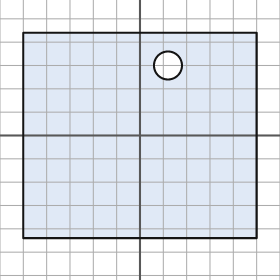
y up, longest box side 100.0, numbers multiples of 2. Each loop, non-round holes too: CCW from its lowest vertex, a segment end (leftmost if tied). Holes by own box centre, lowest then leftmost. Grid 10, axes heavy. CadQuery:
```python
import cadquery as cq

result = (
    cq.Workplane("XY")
    .moveTo(-50.0, -44.0)
    .lineTo(50.0, -44.0)
    .lineTo(50.0, 44.0)
    .lineTo(-50.0, 44.0)
    .close()
    .moveTo(12.0, 30.0)
    .circle(6.0)
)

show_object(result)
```